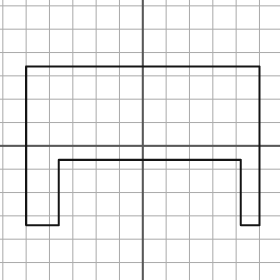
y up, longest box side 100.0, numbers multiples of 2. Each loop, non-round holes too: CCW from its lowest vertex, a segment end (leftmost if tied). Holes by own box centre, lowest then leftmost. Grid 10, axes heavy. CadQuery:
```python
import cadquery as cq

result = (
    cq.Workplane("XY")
    .moveTo(-50.0, -34.0)
    .lineTo(-36.0, -34.0)
    .lineTo(-36.0, -6.0)
    .lineTo(42.0, -6.0)
    .lineTo(42.0, -34.0)
    .lineTo(50.0, -34.0)
    .lineTo(50.0, 34.0)
    .lineTo(-50.0, 34.0)
    .close()
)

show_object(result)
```